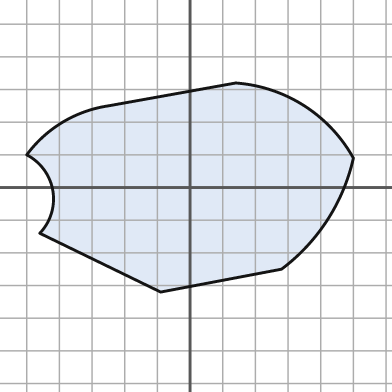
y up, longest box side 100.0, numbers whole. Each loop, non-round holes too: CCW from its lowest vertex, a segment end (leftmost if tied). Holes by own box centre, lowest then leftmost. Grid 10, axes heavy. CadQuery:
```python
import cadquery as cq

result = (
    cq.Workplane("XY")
    .moveTo(-9.0, -32.0)
    .lineTo(28.0, -25.0)
    .threePointArc((42.0, -10.0), (50.0, 9.0))
    .threePointArc((35.0, 25.0), (14.0, 32.0))
    .lineTo(-25.0, 25.0)
    .threePointArc((-39.0, 20.0), (-50.0, 10.0))
    .threePointArc((-42.0, -1.0), (-46.0, -14.0))
    .close()
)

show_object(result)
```